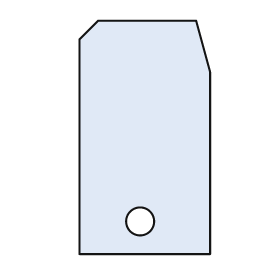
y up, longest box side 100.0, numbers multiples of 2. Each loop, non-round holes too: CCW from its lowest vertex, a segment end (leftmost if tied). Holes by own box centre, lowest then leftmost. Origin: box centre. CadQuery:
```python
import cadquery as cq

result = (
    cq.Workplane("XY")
    .moveTo(-28.0, -50.0)
    .lineTo(28.0, -50.0)
    .lineTo(28.0, 28.0)
    .lineTo(22.0, 50.0)
    .lineTo(-20.0, 50.0)
    .lineTo(-28.0, 42.0)
    .close()
    .moveTo(-2.0, -36.0)
    .circle(6.0)
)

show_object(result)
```